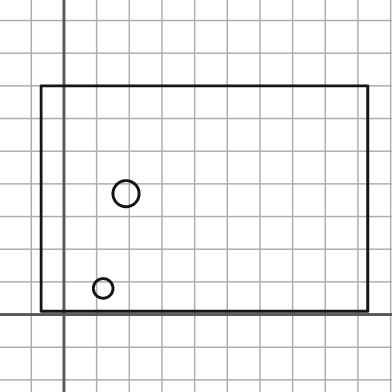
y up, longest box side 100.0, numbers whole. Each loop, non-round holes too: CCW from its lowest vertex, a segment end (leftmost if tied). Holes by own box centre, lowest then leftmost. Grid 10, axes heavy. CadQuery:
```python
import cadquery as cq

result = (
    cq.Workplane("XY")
    .moveTo(-7.0, 1.0)
    .lineTo(93.0, 1.0)
    .lineTo(93.0, 70.0)
    .lineTo(-7.0, 70.0)
    .close()
    .moveTo(12.0, 8.0)
    .circle(3.0)
    .moveTo(19.0, 37.0)
    .circle(4.0)
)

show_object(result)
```